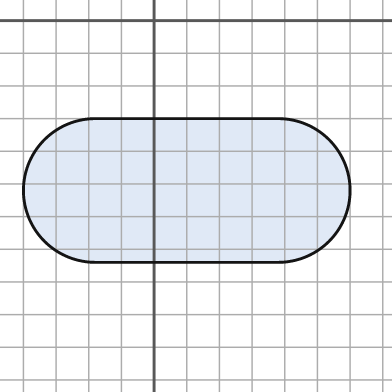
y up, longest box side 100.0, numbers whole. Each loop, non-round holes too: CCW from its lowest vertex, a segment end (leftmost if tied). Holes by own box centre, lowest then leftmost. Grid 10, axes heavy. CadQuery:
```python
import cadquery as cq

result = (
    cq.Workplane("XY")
    .moveTo(-18.0, -74.0)
    .lineTo(38.0, -74.0)
    .threePointArc((60.0, -52.0), (38.0, -30.0))
    .lineTo(-18.0, -30.0)
    .threePointArc((-40.0, -52.0), (-18.0, -74.0))
    .close()
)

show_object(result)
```